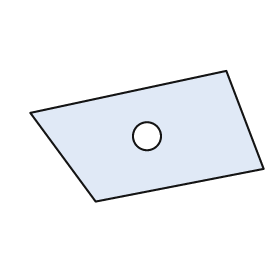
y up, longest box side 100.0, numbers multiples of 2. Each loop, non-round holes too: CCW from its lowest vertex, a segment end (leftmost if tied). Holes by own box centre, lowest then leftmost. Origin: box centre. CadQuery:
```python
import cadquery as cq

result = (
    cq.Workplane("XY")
    .moveTo(-22.0, -28.0)
    .lineTo(50.0, -14.0)
    .lineTo(34.0, 28.0)
    .lineTo(-50.0, 10.0)
    .close()
    .moveTo(0.0, 0.0)
    .circle(6.0)
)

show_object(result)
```